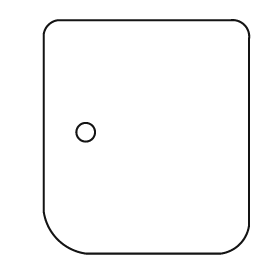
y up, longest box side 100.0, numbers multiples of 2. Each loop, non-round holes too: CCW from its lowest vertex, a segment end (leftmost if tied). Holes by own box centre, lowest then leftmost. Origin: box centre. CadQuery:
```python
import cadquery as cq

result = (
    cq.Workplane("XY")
    .moveTo(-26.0, -50.0)
    .lineTo(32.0, -50.0)
    .threePointArc((40.0, -46.0), (44.0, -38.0))
    .lineTo(44.0, 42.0)
    .threePointArc((42.0, 48.0), (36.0, 50.0))
    .lineTo(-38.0, 50.0)
    .threePointArc((-42.0, 48.0), (-44.0, 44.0))
    .lineTo(-44.0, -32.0)
    .threePointArc((-38.0, -44.0), (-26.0, -50.0))
    .close()
    .moveTo(-26.0, 2.0)
    .circle(4.0)
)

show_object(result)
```